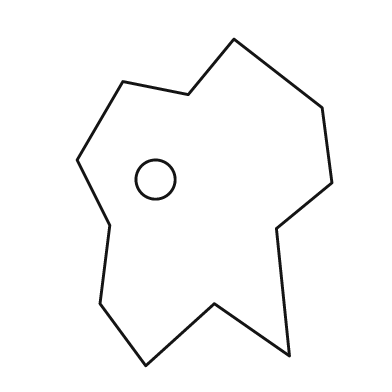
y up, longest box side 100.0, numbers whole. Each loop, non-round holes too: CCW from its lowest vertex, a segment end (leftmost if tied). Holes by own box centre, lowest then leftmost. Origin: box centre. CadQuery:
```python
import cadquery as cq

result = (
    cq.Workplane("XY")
    .moveTo(-18.0, -50.0)
    .lineTo(3.0, -31.0)
    .lineTo(26.0, -47.0)
    .lineTo(22.0, -8.0)
    .lineTo(39.0, 6.0)
    .lineTo(36.0, 29.0)
    .lineTo(9.0, 50.0)
    .lineTo(-5.0, 33.0)
    .lineTo(-25.0, 37.0)
    .lineTo(-39.0, 13.0)
    .lineTo(-29.0, -7.0)
    .lineTo(-32.0, -31.0)
    .close()
    .moveTo(-15.0, 7.0)
    .circle(6.0)
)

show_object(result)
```